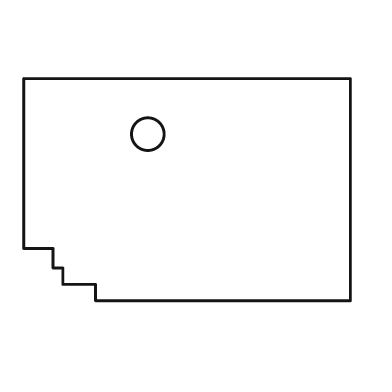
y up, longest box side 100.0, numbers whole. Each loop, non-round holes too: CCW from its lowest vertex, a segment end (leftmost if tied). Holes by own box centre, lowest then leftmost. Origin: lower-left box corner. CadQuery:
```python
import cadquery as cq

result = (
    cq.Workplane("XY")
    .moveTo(22.0, 0.0)
    .lineTo(100.0, 0.0)
    .lineTo(100.0, 68.0)
    .lineTo(0.0, 68.0)
    .lineTo(0.0, 16.0)
    .lineTo(9.0, 16.0)
    .lineTo(9.0, 10.0)
    .lineTo(12.0, 10.0)
    .lineTo(12.0, 5.0)
    .lineTo(22.0, 5.0)
    .close()
    .moveTo(38.0, 51.0)
    .circle(5.0)
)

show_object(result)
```